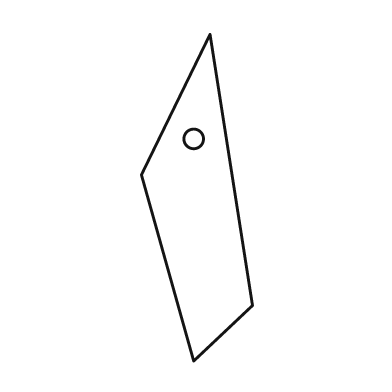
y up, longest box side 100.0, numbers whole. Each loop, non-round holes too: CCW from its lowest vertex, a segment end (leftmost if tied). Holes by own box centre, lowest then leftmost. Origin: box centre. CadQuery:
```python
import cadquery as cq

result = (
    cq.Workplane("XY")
    .moveTo(-1.0, -50.0)
    .lineTo(17.0, -33.0)
    .lineTo(4.0, 50.0)
    .lineTo(-17.0, 7.0)
    .close()
    .moveTo(-1.0, 18.0)
    .circle(3.0)
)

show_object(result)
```